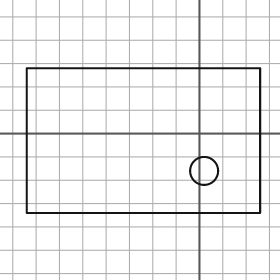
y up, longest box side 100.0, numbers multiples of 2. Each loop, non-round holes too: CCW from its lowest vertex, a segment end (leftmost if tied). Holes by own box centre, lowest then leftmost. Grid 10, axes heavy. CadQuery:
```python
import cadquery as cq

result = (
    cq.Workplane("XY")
    .moveTo(-74.0, -34.0)
    .lineTo(26.0, -34.0)
    .lineTo(26.0, 28.0)
    .lineTo(-74.0, 28.0)
    .close()
    .moveTo(2.0, -16.0)
    .circle(6.0)
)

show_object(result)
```